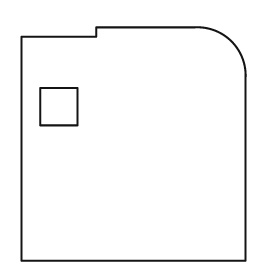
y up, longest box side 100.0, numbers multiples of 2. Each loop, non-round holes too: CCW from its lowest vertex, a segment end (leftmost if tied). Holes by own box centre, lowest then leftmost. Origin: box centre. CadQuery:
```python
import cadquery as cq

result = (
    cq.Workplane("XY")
    .moveTo(-48.0, -50.0)
    .lineTo(48.0, -50.0)
    .lineTo(48.0, 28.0)
    .threePointArc((42.0, 44.0), (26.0, 50.0))
    .lineTo(-16.0, 50.0)
    .lineTo(-16.0, 46.0)
    .lineTo(-48.0, 46.0)
    .close()
    .moveTo(-40.0, 8.0)
    .lineTo(-24.0, 8.0)
    .lineTo(-24.0, 24.0)
    .lineTo(-40.0, 24.0)
    .close()
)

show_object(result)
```